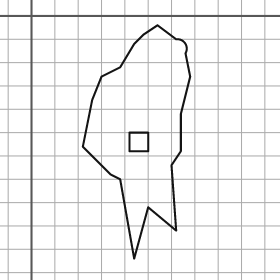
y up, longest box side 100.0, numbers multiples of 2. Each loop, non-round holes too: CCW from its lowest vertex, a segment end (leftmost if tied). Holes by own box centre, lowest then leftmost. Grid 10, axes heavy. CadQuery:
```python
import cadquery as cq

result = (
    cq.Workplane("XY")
    .moveTo(44.0, -104.0)
    .lineTo(50.0, -82.0)
    .lineTo(62.0, -92.0)
    .lineTo(60.0, -64.0)
    .lineTo(64.0, -58.0)
    .lineTo(64.0, -42.0)
    .lineTo(68.0, -26.0)
    .lineTo(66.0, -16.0)
    .threePointArc((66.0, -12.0), (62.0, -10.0))
    .lineTo(54.0, -4.0)
    .lineTo(48.0, -8.0)
    .lineTo(44.0, -12.0)
    .lineTo(38.0, -22.0)
    .lineTo(30.0, -26.0)
    .lineTo(26.0, -36.0)
    .lineTo(22.0, -56.0)
    .lineTo(34.0, -68.0)
    .lineTo(38.0, -70.0)
    .close()
    .moveTo(42.0, -58.0)
    .lineTo(50.0, -58.0)
    .lineTo(50.0, -50.0)
    .lineTo(42.0, -50.0)
    .close()
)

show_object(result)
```